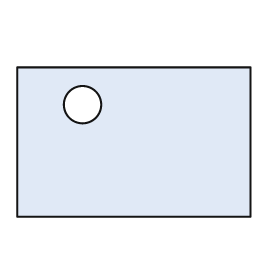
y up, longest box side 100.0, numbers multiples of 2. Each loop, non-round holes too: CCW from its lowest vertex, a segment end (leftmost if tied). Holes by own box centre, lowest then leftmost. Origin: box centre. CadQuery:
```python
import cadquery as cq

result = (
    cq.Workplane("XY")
    .moveTo(-50.0, -32.0)
    .lineTo(50.0, -32.0)
    .lineTo(50.0, 32.0)
    .lineTo(-50.0, 32.0)
    .close()
    .moveTo(-22.0, 16.0)
    .circle(8.0)
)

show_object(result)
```